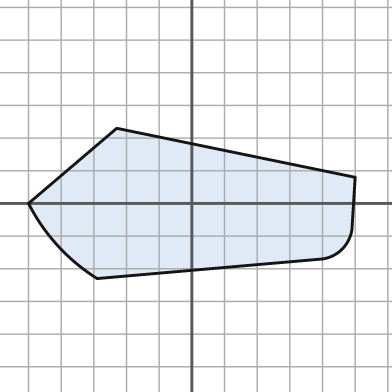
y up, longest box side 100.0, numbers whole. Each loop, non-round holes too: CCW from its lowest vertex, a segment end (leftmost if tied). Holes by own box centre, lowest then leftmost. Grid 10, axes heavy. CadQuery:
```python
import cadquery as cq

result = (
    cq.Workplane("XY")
    .moveTo(-29.0, -23.0)
    .lineTo(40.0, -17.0)
    .threePointArc((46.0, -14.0), (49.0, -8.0))
    .lineTo(50.0, 8.0)
    .lineTo(-23.0, 23.0)
    .lineTo(-50.0, 0.0)
    .threePointArc((-41.0, -13.0), (-29.0, -23.0))
    .close()
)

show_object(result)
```